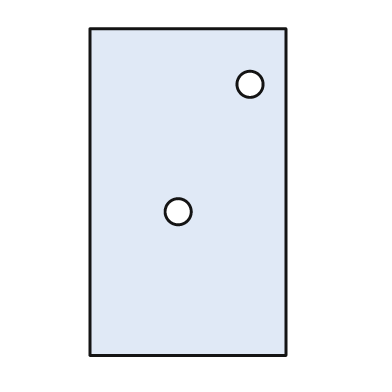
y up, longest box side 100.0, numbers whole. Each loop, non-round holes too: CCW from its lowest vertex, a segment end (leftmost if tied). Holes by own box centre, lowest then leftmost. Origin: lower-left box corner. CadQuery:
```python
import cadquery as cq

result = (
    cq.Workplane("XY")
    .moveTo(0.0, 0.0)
    .lineTo(60.0, 0.0)
    .lineTo(60.0, 100.0)
    .lineTo(0.0, 100.0)
    .close()
    .moveTo(27.0, 44.0)
    .circle(4.0)
    .moveTo(49.0, 83.0)
    .circle(4.0)
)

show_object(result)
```